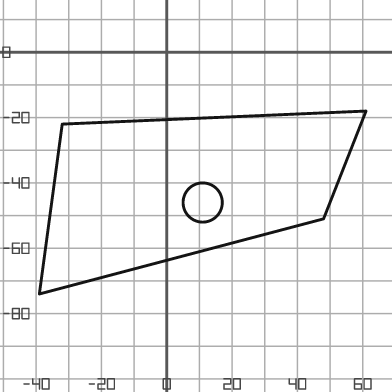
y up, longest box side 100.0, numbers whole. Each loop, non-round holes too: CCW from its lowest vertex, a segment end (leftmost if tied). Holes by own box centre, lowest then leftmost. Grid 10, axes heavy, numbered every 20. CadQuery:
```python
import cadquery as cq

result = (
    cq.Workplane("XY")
    .moveTo(-39.0, -74.0)
    .lineTo(48.0, -51.0)
    .lineTo(61.0, -18.0)
    .lineTo(-32.0, -22.0)
    .close()
    .moveTo(11.0, -46.0)
    .circle(6.0)
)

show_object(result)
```